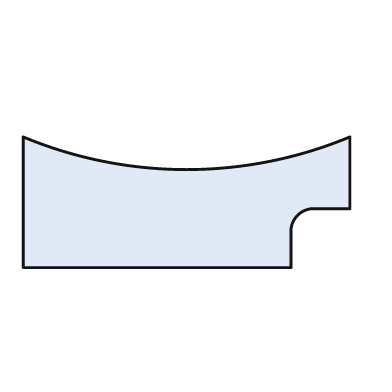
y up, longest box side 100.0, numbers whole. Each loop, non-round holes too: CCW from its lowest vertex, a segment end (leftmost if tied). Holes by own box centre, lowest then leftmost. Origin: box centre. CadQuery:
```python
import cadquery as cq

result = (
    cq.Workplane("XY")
    .moveTo(-50.0, -20.0)
    .lineTo(32.0, -20.0)
    .lineTo(32.0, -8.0)
    .threePointArc((34.0, -4.0), (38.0, -2.0))
    .lineTo(50.0, -2.0)
    .lineTo(50.0, 20.0)
    .threePointArc((0.0, 10.0), (-50.0, 20.0))
    .close()
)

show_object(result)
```